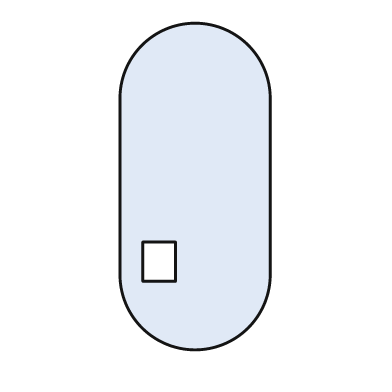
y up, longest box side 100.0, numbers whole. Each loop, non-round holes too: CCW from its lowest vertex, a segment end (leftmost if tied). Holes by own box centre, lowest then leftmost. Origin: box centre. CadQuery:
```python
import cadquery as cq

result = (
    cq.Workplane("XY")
    .moveTo(-23.0, -27.0)
    .threePointArc((0.0, -50.0), (23.0, -27.0))
    .lineTo(23.0, 27.0)
    .threePointArc((0.0, 50.0), (-23.0, 27.0))
    .close()
    .moveTo(-16.0, -29.0)
    .lineTo(-6.0, -29.0)
    .lineTo(-6.0, -17.0)
    .lineTo(-16.0, -17.0)
    .close()
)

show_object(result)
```